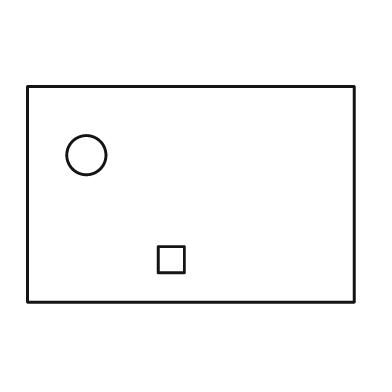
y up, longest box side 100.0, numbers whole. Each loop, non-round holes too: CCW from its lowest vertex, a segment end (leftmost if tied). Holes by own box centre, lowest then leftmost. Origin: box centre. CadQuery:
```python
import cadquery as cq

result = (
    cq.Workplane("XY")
    .moveTo(-50.0, -33.0)
    .lineTo(50.0, -33.0)
    .lineTo(50.0, 33.0)
    .lineTo(-50.0, 33.0)
    .close()
    .moveTo(-10.0, -24.0)
    .lineTo(-2.0, -24.0)
    .lineTo(-2.0, -16.0)
    .lineTo(-10.0, -16.0)
    .close()
    .moveTo(-32.0, 12.0)
    .circle(6.0)
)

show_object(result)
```